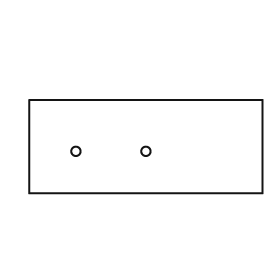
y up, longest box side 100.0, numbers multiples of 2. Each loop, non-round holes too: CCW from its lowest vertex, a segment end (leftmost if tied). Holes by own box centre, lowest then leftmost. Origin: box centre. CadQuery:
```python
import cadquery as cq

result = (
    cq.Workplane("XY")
    .moveTo(-50.0, -20.0)
    .lineTo(50.0, -20.0)
    .lineTo(50.0, 20.0)
    .lineTo(-50.0, 20.0)
    .close()
    .moveTo(-30.0, -2.0)
    .circle(2.0)
    .moveTo(0.0, -2.0)
    .circle(2.0)
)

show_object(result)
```